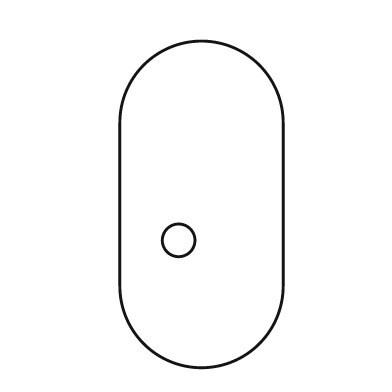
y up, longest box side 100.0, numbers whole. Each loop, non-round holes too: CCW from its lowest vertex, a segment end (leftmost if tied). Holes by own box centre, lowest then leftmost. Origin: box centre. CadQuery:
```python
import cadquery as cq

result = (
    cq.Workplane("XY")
    .moveTo(-25.0, -25.0)
    .threePointArc((0.0, -50.0), (25.0, -25.0))
    .lineTo(25.0, 25.0)
    .threePointArc((0.0, 50.0), (-25.0, 25.0))
    .close()
    .moveTo(-7.0, -11.0)
    .circle(5.0)
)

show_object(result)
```